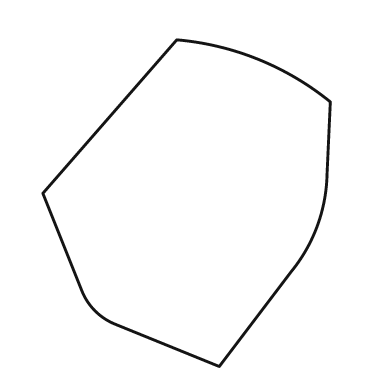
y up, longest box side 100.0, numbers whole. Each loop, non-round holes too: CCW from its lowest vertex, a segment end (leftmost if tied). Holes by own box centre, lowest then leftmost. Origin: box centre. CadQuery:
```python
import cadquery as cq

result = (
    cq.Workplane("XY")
    .moveTo(10.0, -50.0)
    .lineTo(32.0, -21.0)
    .threePointArc((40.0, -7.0), (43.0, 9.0))
    .lineTo(44.0, 31.0)
    .threePointArc((22.0, 44.0), (-3.0, 50.0))
    .lineTo(-44.0, 3.0)
    .lineTo(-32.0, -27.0)
    .threePointArc((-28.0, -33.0), (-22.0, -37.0))
    .close()
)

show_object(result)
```